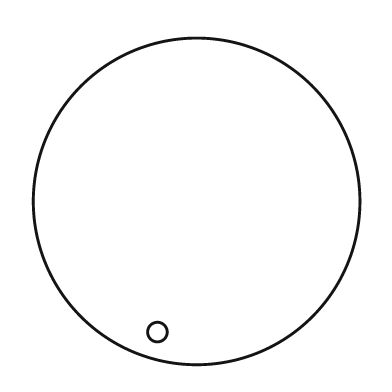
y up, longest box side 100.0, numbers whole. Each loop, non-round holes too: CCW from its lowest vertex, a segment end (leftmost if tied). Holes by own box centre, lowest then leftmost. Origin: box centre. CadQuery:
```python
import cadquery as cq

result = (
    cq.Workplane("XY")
    .moveTo(0.0, 0.0)
    .circle(50.0)
    .moveTo(-12.0, -40.0)
    .circle(3.0)
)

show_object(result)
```